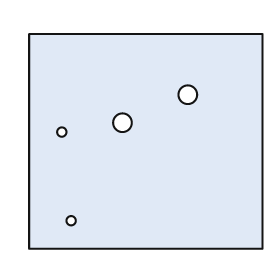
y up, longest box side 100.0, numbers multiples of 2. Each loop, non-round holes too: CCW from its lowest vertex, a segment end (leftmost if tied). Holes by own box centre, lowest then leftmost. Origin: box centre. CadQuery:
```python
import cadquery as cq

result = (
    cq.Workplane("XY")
    .moveTo(-50.0, -46.0)
    .lineTo(50.0, -46.0)
    .lineTo(50.0, 46.0)
    .lineTo(-50.0, 46.0)
    .close()
    .moveTo(-32.0, -34.0)
    .circle(2.0)
    .moveTo(-36.0, 4.0)
    .circle(2.0)
    .moveTo(-10.0, 8.0)
    .circle(4.0)
    .moveTo(18.0, 20.0)
    .circle(4.0)
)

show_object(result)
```